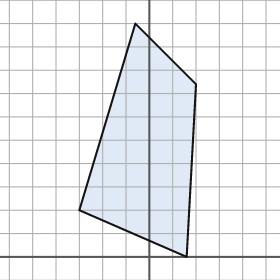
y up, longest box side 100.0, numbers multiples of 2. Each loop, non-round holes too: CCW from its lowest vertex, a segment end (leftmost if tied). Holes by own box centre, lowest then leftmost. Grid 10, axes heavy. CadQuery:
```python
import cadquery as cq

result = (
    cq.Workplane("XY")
    .moveTo(16.0, 0.0)
    .lineTo(20.0, 74.0)
    .lineTo(-6.0, 100.0)
    .lineTo(-30.0, 20.0)
    .close()
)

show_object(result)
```